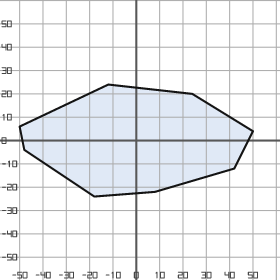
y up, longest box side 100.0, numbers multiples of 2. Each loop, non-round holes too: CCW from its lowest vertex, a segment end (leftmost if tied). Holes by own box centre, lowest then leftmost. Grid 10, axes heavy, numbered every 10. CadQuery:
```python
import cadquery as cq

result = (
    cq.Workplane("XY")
    .moveTo(-18.0, -24.0)
    .lineTo(8.0, -22.0)
    .lineTo(42.0, -12.0)
    .lineTo(50.0, 4.0)
    .lineTo(24.0, 20.0)
    .lineTo(-12.0, 24.0)
    .lineTo(-50.0, 6.0)
    .lineTo(-48.0, -4.0)
    .close()
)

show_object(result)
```